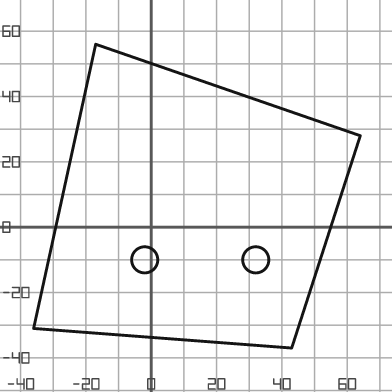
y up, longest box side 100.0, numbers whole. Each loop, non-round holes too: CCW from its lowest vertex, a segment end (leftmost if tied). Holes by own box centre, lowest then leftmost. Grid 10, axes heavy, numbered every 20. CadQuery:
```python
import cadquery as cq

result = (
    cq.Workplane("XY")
    .moveTo(43.0, -37.0)
    .lineTo(64.0, 28.0)
    .lineTo(-17.0, 56.0)
    .lineTo(-36.0, -31.0)
    .close()
    .moveTo(-2.0, -10.0)
    .circle(4.0)
    .moveTo(32.0, -10.0)
    .circle(4.0)
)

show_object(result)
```